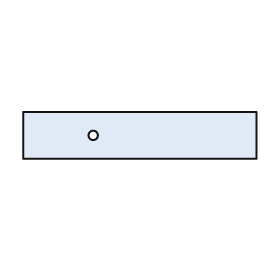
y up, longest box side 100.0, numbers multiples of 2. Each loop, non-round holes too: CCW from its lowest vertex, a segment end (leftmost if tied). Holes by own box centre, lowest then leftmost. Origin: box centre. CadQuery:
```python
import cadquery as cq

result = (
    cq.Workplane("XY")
    .moveTo(-50.0, -10.0)
    .lineTo(50.0, -10.0)
    .lineTo(50.0, 10.0)
    .lineTo(-50.0, 10.0)
    .close()
    .moveTo(-20.0, 0.0)
    .circle(2.0)
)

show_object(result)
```